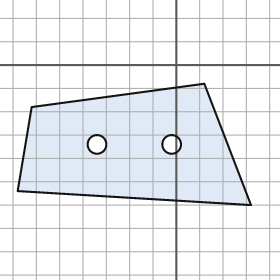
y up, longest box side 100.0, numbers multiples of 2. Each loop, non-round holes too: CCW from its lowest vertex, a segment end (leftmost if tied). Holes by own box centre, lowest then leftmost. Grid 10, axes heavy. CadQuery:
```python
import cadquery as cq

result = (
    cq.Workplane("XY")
    .moveTo(32.0, -60.0)
    .lineTo(12.0, -8.0)
    .lineTo(-62.0, -18.0)
    .lineTo(-68.0, -54.0)
    .close()
    .moveTo(-34.0, -34.0)
    .circle(4.0)
    .moveTo(-2.0, -34.0)
    .circle(4.0)
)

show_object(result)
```